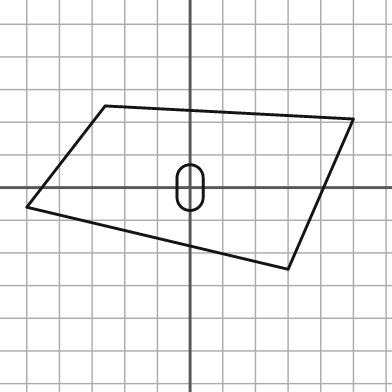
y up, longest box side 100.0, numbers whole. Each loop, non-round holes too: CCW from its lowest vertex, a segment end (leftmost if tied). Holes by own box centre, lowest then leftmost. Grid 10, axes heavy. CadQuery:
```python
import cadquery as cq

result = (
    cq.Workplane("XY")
    .moveTo(30.0, -25.0)
    .lineTo(50.0, 21.0)
    .lineTo(-26.0, 25.0)
    .lineTo(-50.0, -6.0)
    .close()
    .moveTo(-4.0, -3.0)
    .threePointArc((0.0, -7.0), (4.0, -3.0))
    .lineTo(4.0, 3.0)
    .threePointArc((0.0, 7.0), (-4.0, 3.0))
    .close()
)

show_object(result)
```